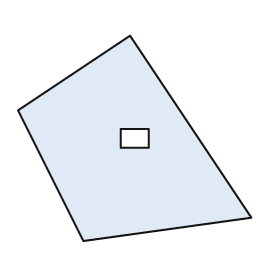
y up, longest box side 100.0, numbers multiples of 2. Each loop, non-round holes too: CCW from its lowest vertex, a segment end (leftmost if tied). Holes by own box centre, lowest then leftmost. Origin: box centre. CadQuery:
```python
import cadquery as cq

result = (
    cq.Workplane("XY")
    .moveTo(-22.0, -44.0)
    .lineTo(50.0, -34.0)
    .lineTo(-2.0, 44.0)
    .lineTo(-50.0, 12.0)
    .close()
    .moveTo(-6.0, -4.0)
    .lineTo(6.0, -4.0)
    .lineTo(6.0, 4.0)
    .lineTo(-6.0, 4.0)
    .close()
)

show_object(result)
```